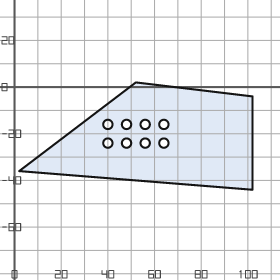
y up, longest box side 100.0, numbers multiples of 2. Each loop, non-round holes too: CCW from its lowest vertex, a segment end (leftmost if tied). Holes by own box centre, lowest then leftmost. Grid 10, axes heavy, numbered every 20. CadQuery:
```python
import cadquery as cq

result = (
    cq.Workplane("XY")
    .moveTo(102.0, -44.0)
    .lineTo(102.0, -4.0)
    .lineTo(52.0, 2.0)
    .lineTo(2.0, -36.0)
    .close()
    .moveTo(40.0, -24.0)
    .circle(2.0)
    .moveTo(48.0, -24.0)
    .circle(2.0)
    .moveTo(56.0, -24.0)
    .circle(2.0)
    .moveTo(64.0, -24.0)
    .circle(2.0)
    .moveTo(40.0, -16.0)
    .circle(2.0)
    .moveTo(48.0, -16.0)
    .circle(2.0)
    .moveTo(56.0, -16.0)
    .circle(2.0)
    .moveTo(64.0, -16.0)
    .circle(2.0)
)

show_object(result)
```